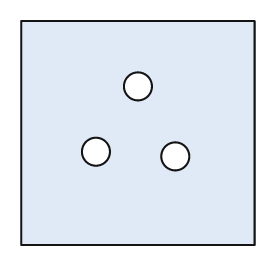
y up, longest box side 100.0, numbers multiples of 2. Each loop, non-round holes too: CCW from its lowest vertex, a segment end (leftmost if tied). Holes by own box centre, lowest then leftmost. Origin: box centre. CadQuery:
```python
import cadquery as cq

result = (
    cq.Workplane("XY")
    .moveTo(-50.0, -48.0)
    .lineTo(50.0, -48.0)
    .lineTo(50.0, 48.0)
    .lineTo(-50.0, 48.0)
    .close()
    .moveTo(16.0, -10.0)
    .circle(6.0)
    .moveTo(-18.0, -8.0)
    .circle(6.0)
    .moveTo(0.0, 20.0)
    .circle(6.0)
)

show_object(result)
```